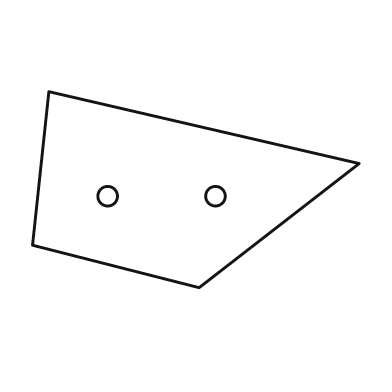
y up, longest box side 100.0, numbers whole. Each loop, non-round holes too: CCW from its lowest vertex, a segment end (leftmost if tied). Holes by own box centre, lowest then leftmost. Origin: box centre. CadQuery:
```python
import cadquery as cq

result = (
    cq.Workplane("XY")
    .moveTo(1.0, -30.0)
    .lineTo(50.0, 8.0)
    .lineTo(-45.0, 30.0)
    .lineTo(-50.0, -17.0)
    .close()
    .moveTo(-27.0, -2.0)
    .circle(3.0)
    .moveTo(6.0, -2.0)
    .circle(3.0)
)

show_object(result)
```